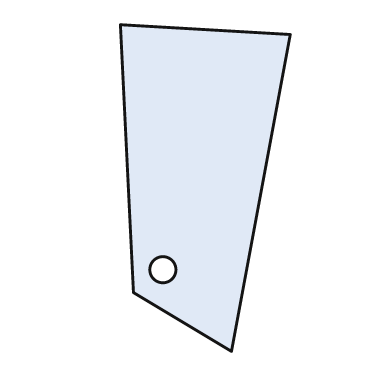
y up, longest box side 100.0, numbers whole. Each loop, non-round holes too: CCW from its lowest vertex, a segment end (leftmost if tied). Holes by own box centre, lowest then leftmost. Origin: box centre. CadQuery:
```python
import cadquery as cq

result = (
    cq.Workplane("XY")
    .moveTo(8.0, -50.0)
    .lineTo(26.0, 47.0)
    .lineTo(-26.0, 50.0)
    .lineTo(-22.0, -32.0)
    .close()
    .moveTo(-13.0, -25.0)
    .circle(4.0)
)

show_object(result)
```